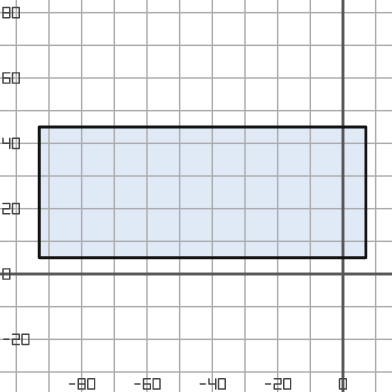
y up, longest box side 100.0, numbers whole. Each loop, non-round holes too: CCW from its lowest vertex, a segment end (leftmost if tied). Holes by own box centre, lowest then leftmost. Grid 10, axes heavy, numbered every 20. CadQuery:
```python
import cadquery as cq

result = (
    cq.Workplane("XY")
    .moveTo(-93.0, 5.0)
    .lineTo(7.0, 5.0)
    .lineTo(7.0, 45.0)
    .lineTo(-93.0, 45.0)
    .close()
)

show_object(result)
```